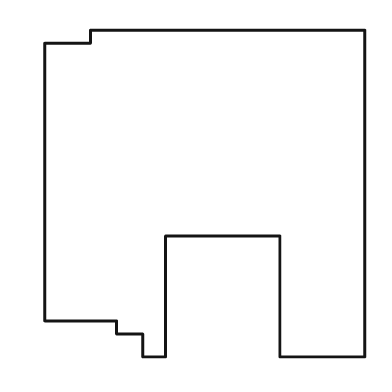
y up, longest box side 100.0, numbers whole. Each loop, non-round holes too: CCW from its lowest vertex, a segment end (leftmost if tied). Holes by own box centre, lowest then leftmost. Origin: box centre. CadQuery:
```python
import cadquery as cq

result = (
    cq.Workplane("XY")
    .moveTo(-19.0, -50.0)
    .lineTo(-12.0, -50.0)
    .lineTo(-12.0, -13.0)
    .lineTo(23.0, -13.0)
    .lineTo(23.0, -50.0)
    .lineTo(49.0, -50.0)
    .lineTo(49.0, 50.0)
    .lineTo(-35.0, 50.0)
    .lineTo(-35.0, 46.0)
    .lineTo(-49.0, 46.0)
    .lineTo(-49.0, -39.0)
    .lineTo(-27.0, -39.0)
    .lineTo(-27.0, -43.0)
    .lineTo(-19.0, -43.0)
    .close()
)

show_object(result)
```